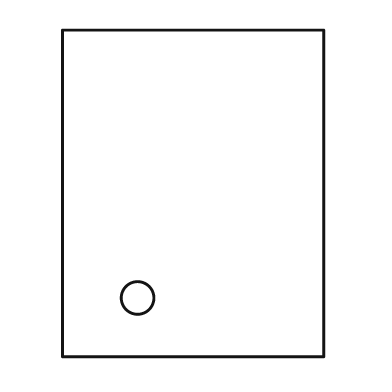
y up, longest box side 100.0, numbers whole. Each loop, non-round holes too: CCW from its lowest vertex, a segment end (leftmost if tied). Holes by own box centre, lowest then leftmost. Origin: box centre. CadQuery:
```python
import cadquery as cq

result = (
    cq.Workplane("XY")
    .moveTo(-40.0, -50.0)
    .lineTo(40.0, -50.0)
    .lineTo(40.0, 50.0)
    .lineTo(-40.0, 50.0)
    .close()
    .moveTo(-17.0, -32.0)
    .circle(5.0)
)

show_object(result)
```